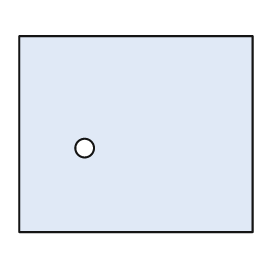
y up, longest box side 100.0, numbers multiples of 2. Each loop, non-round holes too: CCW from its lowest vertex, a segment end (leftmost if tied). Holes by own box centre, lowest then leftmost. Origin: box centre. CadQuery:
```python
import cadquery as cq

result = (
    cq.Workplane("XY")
    .moveTo(-50.0, -42.0)
    .lineTo(50.0, -42.0)
    .lineTo(50.0, 42.0)
    .lineTo(-50.0, 42.0)
    .close()
    .moveTo(-22.0, -6.0)
    .circle(4.0)
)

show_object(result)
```